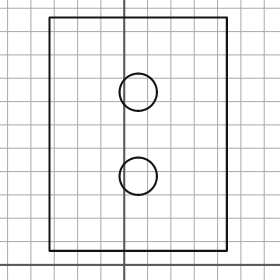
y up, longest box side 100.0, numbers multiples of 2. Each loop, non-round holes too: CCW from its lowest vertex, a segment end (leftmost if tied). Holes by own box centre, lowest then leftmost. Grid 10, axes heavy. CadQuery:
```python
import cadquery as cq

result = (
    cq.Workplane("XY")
    .moveTo(-32.0, 6.0)
    .lineTo(44.0, 6.0)
    .lineTo(44.0, 106.0)
    .lineTo(-32.0, 106.0)
    .close()
    .moveTo(6.0, 38.0)
    .circle(8.0)
    .moveTo(6.0, 74.0)
    .circle(8.0)
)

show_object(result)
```